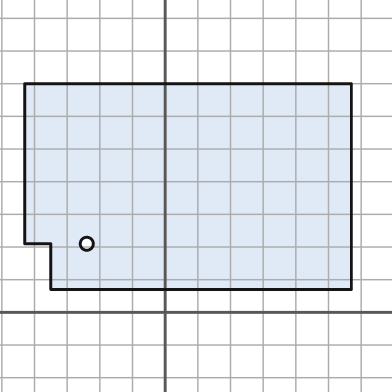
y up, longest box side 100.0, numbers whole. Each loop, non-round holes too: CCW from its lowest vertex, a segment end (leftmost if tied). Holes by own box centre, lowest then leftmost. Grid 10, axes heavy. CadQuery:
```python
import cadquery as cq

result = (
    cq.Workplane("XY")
    .moveTo(-35.0, 7.0)
    .lineTo(57.0, 7.0)
    .lineTo(57.0, 70.0)
    .lineTo(-43.0, 70.0)
    .lineTo(-43.0, 21.0)
    .lineTo(-35.0, 21.0)
    .close()
    .moveTo(-24.0, 21.0)
    .circle(2.0)
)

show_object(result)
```